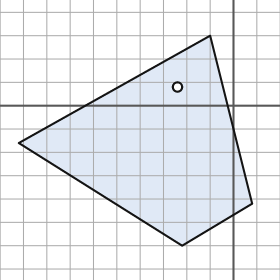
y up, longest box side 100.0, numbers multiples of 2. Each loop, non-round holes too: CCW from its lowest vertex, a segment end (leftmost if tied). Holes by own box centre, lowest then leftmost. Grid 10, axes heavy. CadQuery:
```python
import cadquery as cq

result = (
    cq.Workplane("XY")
    .moveTo(-22.0, -60.0)
    .lineTo(8.0, -42.0)
    .lineTo(-10.0, 30.0)
    .lineTo(-92.0, -16.0)
    .close()
    .moveTo(-24.0, 8.0)
    .circle(2.0)
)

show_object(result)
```